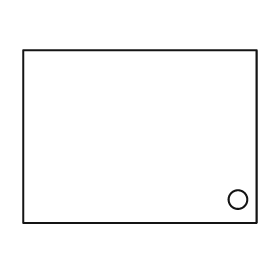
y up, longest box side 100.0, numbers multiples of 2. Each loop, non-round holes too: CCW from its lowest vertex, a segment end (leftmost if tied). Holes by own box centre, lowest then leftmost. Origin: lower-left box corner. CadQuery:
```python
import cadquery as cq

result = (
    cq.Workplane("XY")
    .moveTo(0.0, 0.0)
    .lineTo(100.0, 0.0)
    .lineTo(100.0, 74.0)
    .lineTo(0.0, 74.0)
    .close()
    .moveTo(92.0, 10.0)
    .circle(4.0)
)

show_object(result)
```